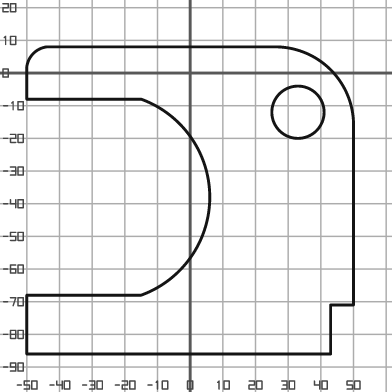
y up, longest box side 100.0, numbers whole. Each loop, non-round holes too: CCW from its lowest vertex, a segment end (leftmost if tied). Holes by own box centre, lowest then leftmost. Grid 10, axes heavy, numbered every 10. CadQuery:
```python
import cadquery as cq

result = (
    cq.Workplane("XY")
    .moveTo(-50.0, -86.0)
    .lineTo(43.0, -86.0)
    .lineTo(43.0, -71.0)
    .lineTo(50.0, -71.0)
    .lineTo(50.0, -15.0)
    .threePointArc((43.0, 1.0), (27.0, 8.0))
    .lineTo(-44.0, 8.0)
    .threePointArc((-48.0, 6.0), (-50.0, 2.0))
    .lineTo(-50.0, -8.0)
    .lineTo(-15.0, -8.0)
    .threePointArc((6.0, -38.0), (-15.0, -68.0))
    .lineTo(-50.0, -68.0)
    .close()
    .moveTo(33.0, -12.0)
    .circle(8.0)
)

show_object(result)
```